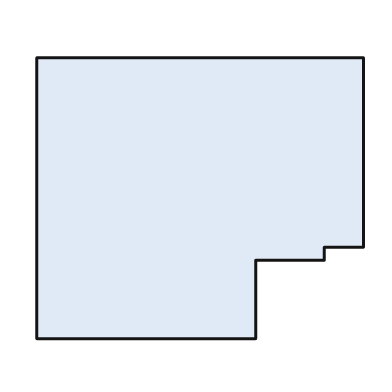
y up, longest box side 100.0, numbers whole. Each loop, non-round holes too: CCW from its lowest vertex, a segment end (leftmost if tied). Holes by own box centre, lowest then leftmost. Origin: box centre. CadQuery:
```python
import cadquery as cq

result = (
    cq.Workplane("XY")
    .moveTo(-50.0, -43.0)
    .lineTo(17.0, -43.0)
    .lineTo(17.0, -19.0)
    .lineTo(38.0, -19.0)
    .lineTo(38.0, -15.0)
    .lineTo(50.0, -15.0)
    .lineTo(50.0, 43.0)
    .lineTo(-50.0, 43.0)
    .close()
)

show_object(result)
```